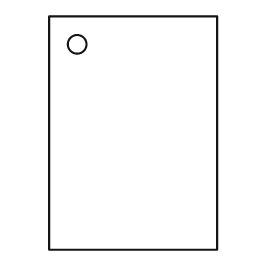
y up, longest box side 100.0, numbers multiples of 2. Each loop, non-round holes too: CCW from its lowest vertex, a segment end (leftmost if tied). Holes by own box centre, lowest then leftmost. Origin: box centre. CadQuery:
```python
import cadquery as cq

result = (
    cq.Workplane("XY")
    .moveTo(-36.0, -50.0)
    .lineTo(36.0, -50.0)
    .lineTo(36.0, 50.0)
    .lineTo(-36.0, 50.0)
    .close()
    .moveTo(-24.0, 38.0)
    .circle(4.0)
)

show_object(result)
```